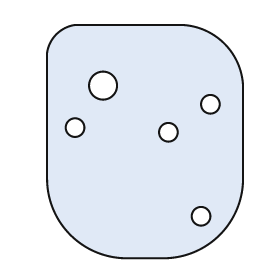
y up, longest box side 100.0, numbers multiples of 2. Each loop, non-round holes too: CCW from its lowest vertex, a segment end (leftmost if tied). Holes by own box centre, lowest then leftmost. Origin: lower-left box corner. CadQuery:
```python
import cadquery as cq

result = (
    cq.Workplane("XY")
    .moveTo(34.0, 0.0)
    .lineTo(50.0, 0.0)
    .threePointArc((74.0, 10.0), (84.0, 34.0))
    .lineTo(84.0, 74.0)
    .threePointArc((76.0, 92.0), (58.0, 100.0))
    .lineTo(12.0, 100.0)
    .threePointArc((4.0, 96.0), (0.0, 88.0))
    .lineTo(0.0, 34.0)
    .threePointArc((10.0, 10.0), (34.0, 0.0))
    .close()
    .moveTo(66.0, 18.0)
    .circle(4.0)
    .moveTo(52.0, 54.0)
    .circle(4.0)
    .moveTo(12.0, 56.0)
    .circle(4.0)
    .moveTo(70.0, 66.0)
    .circle(4.0)
    .moveTo(24.0, 74.0)
    .circle(6.0)
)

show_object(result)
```